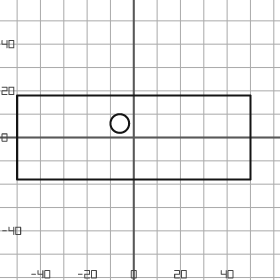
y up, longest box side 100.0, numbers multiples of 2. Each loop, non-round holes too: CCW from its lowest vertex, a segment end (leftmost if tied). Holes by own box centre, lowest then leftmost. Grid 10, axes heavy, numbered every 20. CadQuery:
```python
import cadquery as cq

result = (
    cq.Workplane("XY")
    .moveTo(-50.0, -18.0)
    .lineTo(50.0, -18.0)
    .lineTo(50.0, 18.0)
    .lineTo(-50.0, 18.0)
    .close()
    .moveTo(-6.0, 6.0)
    .circle(4.0)
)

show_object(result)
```